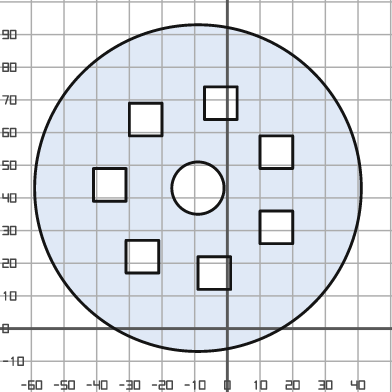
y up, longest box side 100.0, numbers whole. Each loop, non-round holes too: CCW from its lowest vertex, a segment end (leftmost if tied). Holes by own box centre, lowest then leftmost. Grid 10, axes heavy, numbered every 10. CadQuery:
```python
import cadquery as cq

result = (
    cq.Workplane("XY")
    .moveTo(-9.0, 43.0)
    .circle(50.0)
    .moveTo(-9.0, 12.0)
    .lineTo(1.0, 12.0)
    .lineTo(1.0, 22.0)
    .lineTo(-9.0, 22.0)
    .close()
    .moveTo(-31.0, 17.0)
    .lineTo(-21.0, 17.0)
    .lineTo(-21.0, 27.0)
    .lineTo(-31.0, 27.0)
    .close()
    .moveTo(10.0, 26.0)
    .lineTo(20.0, 26.0)
    .lineTo(20.0, 36.0)
    .lineTo(10.0, 36.0)
    .close()
    .moveTo(-9.0, 43.0)
    .circle(8.0)
    .moveTo(-41.0, 39.0)
    .lineTo(-31.0, 39.0)
    .lineTo(-31.0, 49.0)
    .lineTo(-41.0, 49.0)
    .close()
    .moveTo(10.0, 49.0)
    .lineTo(20.0, 49.0)
    .lineTo(20.0, 59.0)
    .lineTo(10.0, 59.0)
    .close()
    .moveTo(-30.0, 59.0)
    .lineTo(-20.0, 59.0)
    .lineTo(-20.0, 69.0)
    .lineTo(-30.0, 69.0)
    .close()
    .moveTo(-7.0, 64.0)
    .lineTo(3.0, 64.0)
    .lineTo(3.0, 74.0)
    .lineTo(-7.0, 74.0)
    .close()
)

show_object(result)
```